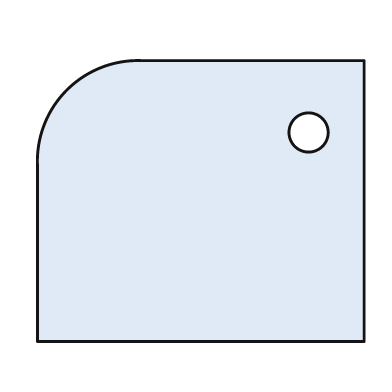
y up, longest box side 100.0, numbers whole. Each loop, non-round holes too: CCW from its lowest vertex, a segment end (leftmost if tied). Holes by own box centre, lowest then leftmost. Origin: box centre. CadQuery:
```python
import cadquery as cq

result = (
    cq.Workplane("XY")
    .moveTo(-50.0, -43.0)
    .lineTo(50.0, -43.0)
    .lineTo(50.0, 43.0)
    .lineTo(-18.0, 43.0)
    .threePointArc((-41.0, 34.0), (-50.0, 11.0))
    .close()
    .moveTo(33.0, 21.0)
    .circle(6.0)
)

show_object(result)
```